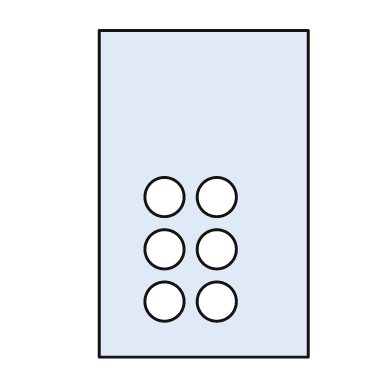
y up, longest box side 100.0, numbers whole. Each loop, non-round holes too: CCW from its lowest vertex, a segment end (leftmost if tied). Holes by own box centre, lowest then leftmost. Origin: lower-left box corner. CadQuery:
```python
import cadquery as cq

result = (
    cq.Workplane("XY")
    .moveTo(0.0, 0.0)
    .lineTo(64.0, 0.0)
    .lineTo(64.0, 100.0)
    .lineTo(0.0, 100.0)
    .close()
    .moveTo(20.0, 17.0)
    .circle(6.0)
    .moveTo(36.0, 17.0)
    .circle(6.0)
    .moveTo(20.0, 33.0)
    .circle(6.0)
    .moveTo(36.0, 33.0)
    .circle(6.0)
    .moveTo(20.0, 49.0)
    .circle(6.0)
    .moveTo(36.0, 49.0)
    .circle(6.0)
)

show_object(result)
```